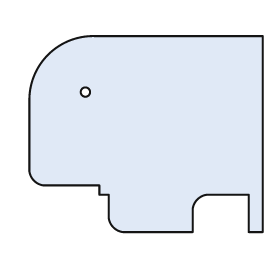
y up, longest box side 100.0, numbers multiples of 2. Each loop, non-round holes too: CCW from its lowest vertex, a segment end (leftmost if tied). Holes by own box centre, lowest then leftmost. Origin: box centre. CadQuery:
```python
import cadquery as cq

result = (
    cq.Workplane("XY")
    .moveTo(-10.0, -42.0)
    .lineTo(20.0, -42.0)
    .lineTo(20.0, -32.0)
    .threePointArc((22.0, -28.0), (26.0, -26.0))
    .lineTo(44.0, -26.0)
    .lineTo(44.0, -42.0)
    .lineTo(50.0, -42.0)
    .lineTo(50.0, 42.0)
    .lineTo(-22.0, 42.0)
    .threePointArc((-42.0, 34.0), (-50.0, 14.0))
    .lineTo(-50.0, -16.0)
    .threePointArc((-48.0, -20.0), (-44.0, -22.0))
    .lineTo(-20.0, -22.0)
    .lineTo(-20.0, -26.0)
    .lineTo(-16.0, -26.0)
    .lineTo(-16.0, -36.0)
    .threePointArc((-14.0, -40.0), (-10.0, -42.0))
    .close()
    .moveTo(-26.0, 18.0)
    .circle(2.0)
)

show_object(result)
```